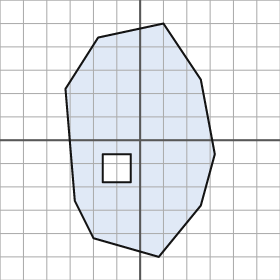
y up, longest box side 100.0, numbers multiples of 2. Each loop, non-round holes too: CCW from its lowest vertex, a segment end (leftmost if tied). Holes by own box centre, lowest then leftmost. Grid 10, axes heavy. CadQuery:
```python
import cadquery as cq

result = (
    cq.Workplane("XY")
    .moveTo(8.0, -50.0)
    .lineTo(26.0, -28.0)
    .lineTo(32.0, -6.0)
    .lineTo(26.0, 26.0)
    .lineTo(10.0, 50.0)
    .lineTo(-18.0, 44.0)
    .lineTo(-32.0, 22.0)
    .lineTo(-28.0, -26.0)
    .lineTo(-20.0, -42.0)
    .close()
    .moveTo(-16.0, -18.0)
    .lineTo(-4.0, -18.0)
    .lineTo(-4.0, -6.0)
    .lineTo(-16.0, -6.0)
    .close()
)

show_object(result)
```